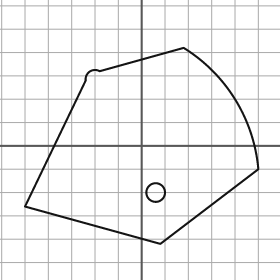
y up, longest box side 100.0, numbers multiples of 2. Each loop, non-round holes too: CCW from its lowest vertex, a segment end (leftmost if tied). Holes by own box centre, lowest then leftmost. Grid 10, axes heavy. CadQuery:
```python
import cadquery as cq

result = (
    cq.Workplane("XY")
    .moveTo(8.0, -42.0)
    .lineTo(50.0, -10.0)
    .threePointArc((40.0, 20.0), (18.0, 42.0))
    .lineTo(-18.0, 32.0)
    .threePointArc((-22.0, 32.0), (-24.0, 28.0))
    .lineTo(-50.0, -26.0)
    .close()
    .moveTo(6.0, -20.0)
    .circle(4.0)
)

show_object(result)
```